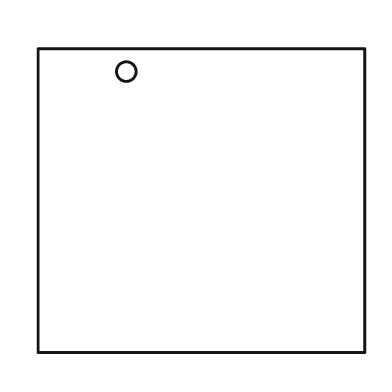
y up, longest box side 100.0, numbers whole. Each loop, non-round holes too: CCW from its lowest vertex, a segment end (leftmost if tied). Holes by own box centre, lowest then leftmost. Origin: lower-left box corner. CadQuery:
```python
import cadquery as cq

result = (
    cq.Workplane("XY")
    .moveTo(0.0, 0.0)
    .lineTo(100.0, 0.0)
    .lineTo(100.0, 93.0)
    .lineTo(0.0, 93.0)
    .close()
    .moveTo(27.0, 86.0)
    .circle(3.0)
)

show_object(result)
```